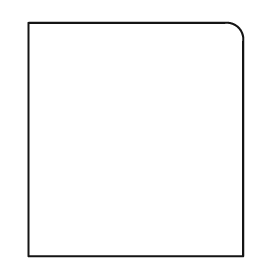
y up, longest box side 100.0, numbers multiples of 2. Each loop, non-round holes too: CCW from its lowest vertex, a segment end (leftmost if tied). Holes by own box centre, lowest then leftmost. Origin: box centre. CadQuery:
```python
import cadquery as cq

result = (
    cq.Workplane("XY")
    .moveTo(-46.0, -50.0)
    .lineTo(46.0, -50.0)
    .lineTo(46.0, 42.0)
    .threePointArc((44.0, 48.0), (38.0, 50.0))
    .lineTo(-46.0, 50.0)
    .close()
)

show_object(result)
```